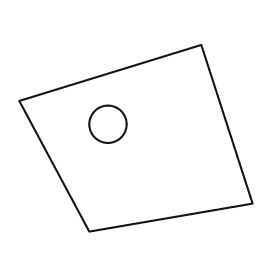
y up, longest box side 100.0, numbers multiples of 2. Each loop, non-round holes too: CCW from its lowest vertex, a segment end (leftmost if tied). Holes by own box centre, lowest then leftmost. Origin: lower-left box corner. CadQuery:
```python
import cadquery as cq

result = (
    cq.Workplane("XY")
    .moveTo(30.0, 0.0)
    .lineTo(100.0, 12.0)
    .lineTo(78.0, 80.0)
    .lineTo(0.0, 56.0)
    .close()
    .moveTo(38.0, 46.0)
    .circle(8.0)
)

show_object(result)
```